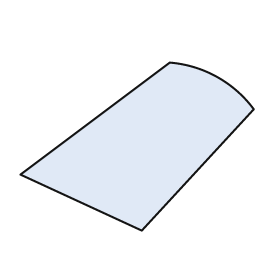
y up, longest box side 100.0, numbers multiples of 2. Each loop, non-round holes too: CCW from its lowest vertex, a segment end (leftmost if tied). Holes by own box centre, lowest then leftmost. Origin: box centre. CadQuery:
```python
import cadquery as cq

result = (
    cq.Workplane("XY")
    .moveTo(2.0, -36.0)
    .lineTo(50.0, 16.0)
    .threePointArc((34.0, 30.0), (14.0, 36.0))
    .lineTo(-50.0, -12.0)
    .close()
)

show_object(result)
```